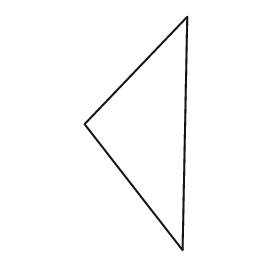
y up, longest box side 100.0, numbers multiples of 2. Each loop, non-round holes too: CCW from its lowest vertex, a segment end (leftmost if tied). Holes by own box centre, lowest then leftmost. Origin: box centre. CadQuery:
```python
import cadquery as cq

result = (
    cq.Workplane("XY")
    .moveTo(20.0, -50.0)
    .lineTo(22.0, 50.0)
    .lineTo(-22.0, 4.0)
    .close()
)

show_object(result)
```